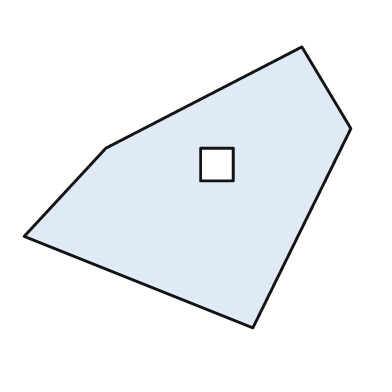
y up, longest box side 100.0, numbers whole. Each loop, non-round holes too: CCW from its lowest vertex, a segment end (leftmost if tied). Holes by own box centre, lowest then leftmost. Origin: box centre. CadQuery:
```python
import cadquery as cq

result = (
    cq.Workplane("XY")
    .moveTo(20.0, -43.0)
    .lineTo(50.0, 18.0)
    .lineTo(35.0, 43.0)
    .lineTo(-25.0, 12.0)
    .lineTo(-50.0, -15.0)
    .close()
    .moveTo(4.0, 2.0)
    .lineTo(14.0, 2.0)
    .lineTo(14.0, 12.0)
    .lineTo(4.0, 12.0)
    .close()
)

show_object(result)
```